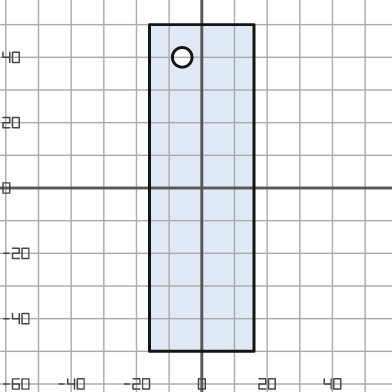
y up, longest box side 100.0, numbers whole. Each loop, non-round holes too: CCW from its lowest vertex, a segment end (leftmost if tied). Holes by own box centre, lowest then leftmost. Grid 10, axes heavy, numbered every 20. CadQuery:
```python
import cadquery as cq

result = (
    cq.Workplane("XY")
    .moveTo(-16.0, -50.0)
    .lineTo(16.0, -50.0)
    .lineTo(16.0, 50.0)
    .lineTo(-16.0, 50.0)
    .close()
    .moveTo(-6.0, 40.0)
    .circle(3.0)
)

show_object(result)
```